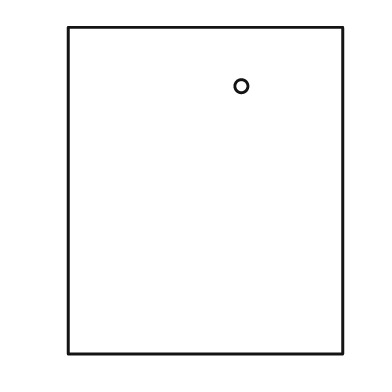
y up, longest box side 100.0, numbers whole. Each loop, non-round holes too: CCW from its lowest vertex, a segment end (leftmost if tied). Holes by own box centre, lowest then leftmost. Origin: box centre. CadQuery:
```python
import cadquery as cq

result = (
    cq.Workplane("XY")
    .moveTo(-42.0, -50.0)
    .lineTo(42.0, -50.0)
    .lineTo(42.0, 50.0)
    .lineTo(-42.0, 50.0)
    .close()
    .moveTo(11.0, 32.0)
    .circle(2.0)
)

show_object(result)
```